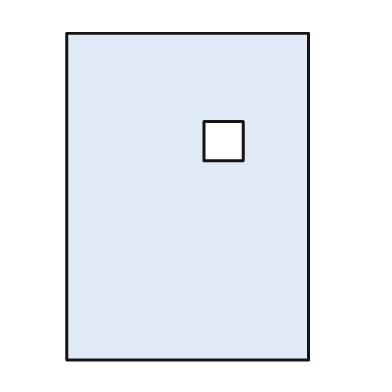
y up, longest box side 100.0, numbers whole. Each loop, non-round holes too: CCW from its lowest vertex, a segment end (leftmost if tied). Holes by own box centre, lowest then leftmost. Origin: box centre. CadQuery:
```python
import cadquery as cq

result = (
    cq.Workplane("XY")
    .moveTo(-37.0, -50.0)
    .lineTo(37.0, -50.0)
    .lineTo(37.0, 50.0)
    .lineTo(-37.0, 50.0)
    .close()
    .moveTo(5.0, 11.0)
    .lineTo(17.0, 11.0)
    .lineTo(17.0, 23.0)
    .lineTo(5.0, 23.0)
    .close()
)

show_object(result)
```